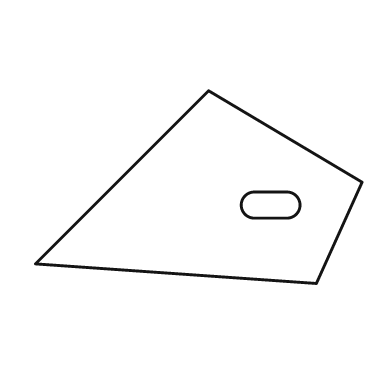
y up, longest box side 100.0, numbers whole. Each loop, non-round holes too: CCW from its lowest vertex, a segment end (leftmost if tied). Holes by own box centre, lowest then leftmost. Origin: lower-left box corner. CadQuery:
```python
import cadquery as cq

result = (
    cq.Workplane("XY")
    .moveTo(86.0, 0.0)
    .lineTo(100.0, 31.0)
    .lineTo(53.0, 59.0)
    .lineTo(0.0, 6.0)
    .close()
    .moveTo(67.0, 20.0)
    .lineTo(77.0, 20.0)
    .threePointArc((81.0, 24.0), (77.0, 28.0))
    .lineTo(67.0, 28.0)
    .threePointArc((63.0, 24.0), (67.0, 20.0))
    .close()
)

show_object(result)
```